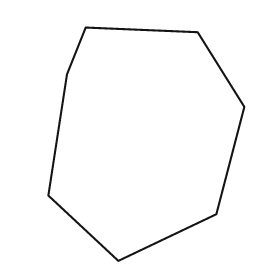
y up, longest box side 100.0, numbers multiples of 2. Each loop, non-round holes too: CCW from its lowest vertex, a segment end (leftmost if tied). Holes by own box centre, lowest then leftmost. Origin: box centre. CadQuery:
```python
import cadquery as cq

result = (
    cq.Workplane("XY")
    .moveTo(-12.0, -50.0)
    .lineTo(30.0, -30.0)
    .lineTo(42.0, 16.0)
    .lineTo(22.0, 48.0)
    .lineTo(-26.0, 50.0)
    .lineTo(-34.0, 30.0)
    .lineTo(-42.0, -22.0)
    .close()
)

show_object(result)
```